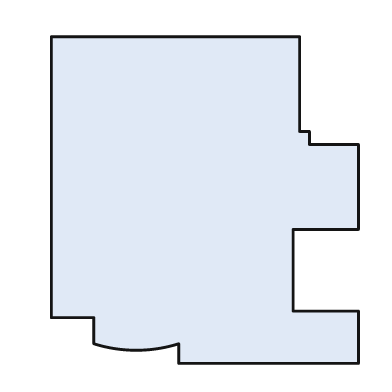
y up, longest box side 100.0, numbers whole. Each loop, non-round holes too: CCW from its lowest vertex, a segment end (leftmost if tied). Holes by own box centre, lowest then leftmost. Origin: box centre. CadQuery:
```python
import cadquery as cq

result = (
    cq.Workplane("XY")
    .moveTo(-8.0, -50.0)
    .lineTo(47.0, -50.0)
    .lineTo(47.0, -34.0)
    .lineTo(27.0, -34.0)
    .lineTo(27.0, -9.0)
    .lineTo(47.0, -9.0)
    .lineTo(47.0, 17.0)
    .lineTo(32.0, 17.0)
    .lineTo(32.0, 21.0)
    .lineTo(29.0, 21.0)
    .lineTo(29.0, 50.0)
    .lineTo(-47.0, 50.0)
    .lineTo(-47.0, -36.0)
    .lineTo(-34.0, -36.0)
    .lineTo(-34.0, -44.0)
    .threePointArc((-21.0, -46.0), (-8.0, -44.0))
    .close()
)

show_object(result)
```